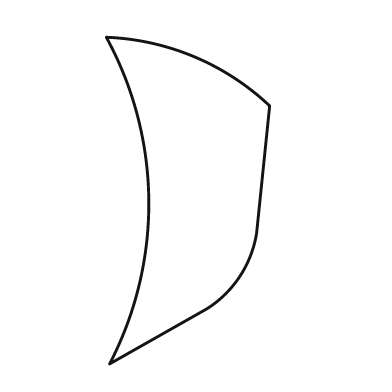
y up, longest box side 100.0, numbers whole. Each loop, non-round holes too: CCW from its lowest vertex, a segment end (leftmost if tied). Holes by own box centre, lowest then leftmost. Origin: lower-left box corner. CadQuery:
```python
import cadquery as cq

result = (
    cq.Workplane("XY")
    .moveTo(1.0, 0.0)
    .lineTo(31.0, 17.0)
    .threePointArc((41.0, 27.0), (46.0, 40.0))
    .lineTo(50.0, 79.0)
    .threePointArc((27.0, 94.0), (0.0, 100.0))
    .threePointArc((13.0, 50.0), (1.0, 0.0))
    .close()
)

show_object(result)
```